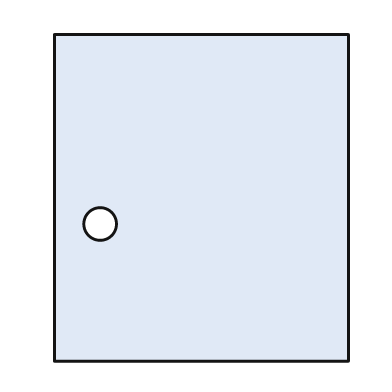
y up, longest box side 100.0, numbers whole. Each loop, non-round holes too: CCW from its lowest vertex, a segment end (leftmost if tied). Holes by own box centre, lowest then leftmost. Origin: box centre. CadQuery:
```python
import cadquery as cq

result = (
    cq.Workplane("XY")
    .moveTo(-45.0, -50.0)
    .lineTo(45.0, -50.0)
    .lineTo(45.0, 50.0)
    .lineTo(-45.0, 50.0)
    .close()
    .moveTo(-31.0, -8.0)
    .circle(5.0)
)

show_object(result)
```